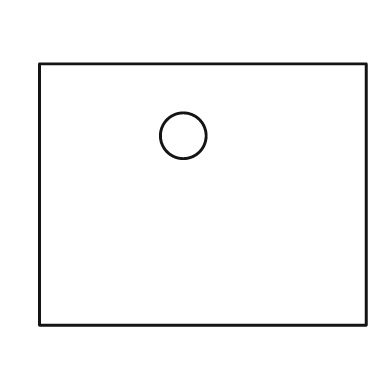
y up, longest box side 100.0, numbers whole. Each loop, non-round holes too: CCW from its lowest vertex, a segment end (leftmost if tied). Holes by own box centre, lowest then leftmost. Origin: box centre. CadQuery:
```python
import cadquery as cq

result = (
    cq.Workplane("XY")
    .moveTo(-50.0, -40.0)
    .lineTo(50.0, -40.0)
    .lineTo(50.0, 40.0)
    .lineTo(-50.0, 40.0)
    .close()
    .moveTo(-6.0, 18.0)
    .circle(7.0)
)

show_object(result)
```